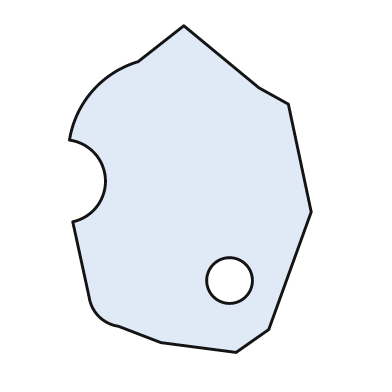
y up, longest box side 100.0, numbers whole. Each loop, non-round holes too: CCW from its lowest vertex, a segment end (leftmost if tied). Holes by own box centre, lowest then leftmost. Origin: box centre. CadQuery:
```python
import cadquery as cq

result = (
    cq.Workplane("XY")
    .moveTo(14.0, -50.0)
    .lineTo(24.0, -43.0)
    .lineTo(37.0, -7.0)
    .lineTo(30.0, 26.0)
    .lineTo(21.0, 31.0)
    .lineTo(-2.0, 50.0)
    .lineTo(-16.0, 39.0)
    .threePointArc((-30.0, 30.0), (-37.0, 15.0))
    .threePointArc((-26.0, 3.0), (-36.0, -10.0))
    .lineTo(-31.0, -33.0)
    .threePointArc((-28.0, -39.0), (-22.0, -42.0))
    .lineTo(-9.0, -47.0)
    .close()
    .moveTo(12.0, -28.0)
    .circle(7.0)
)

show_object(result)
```